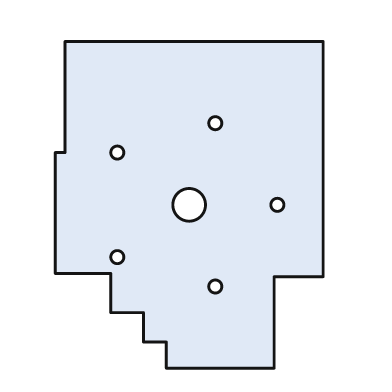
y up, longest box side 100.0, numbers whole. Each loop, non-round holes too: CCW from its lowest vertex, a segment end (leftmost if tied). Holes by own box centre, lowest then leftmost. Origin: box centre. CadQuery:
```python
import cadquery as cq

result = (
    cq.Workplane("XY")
    .moveTo(-7.0, -50.0)
    .lineTo(26.0, -50.0)
    .lineTo(26.0, -22.0)
    .lineTo(41.0, -22.0)
    .lineTo(41.0, 50.0)
    .lineTo(-38.0, 50.0)
    .lineTo(-38.0, 16.0)
    .lineTo(-41.0, 16.0)
    .lineTo(-41.0, -21.0)
    .lineTo(-24.0, -21.0)
    .lineTo(-24.0, -33.0)
    .lineTo(-14.0, -33.0)
    .lineTo(-14.0, -42.0)
    .lineTo(-7.0, -42.0)
    .close()
    .moveTo(8.0, -25.0)
    .circle(2.0)
    .moveTo(-22.0, -16.0)
    .circle(2.0)
    .moveTo(0.0, 0.0)
    .circle(5.0)
    .moveTo(27.0, 0.0)
    .circle(2.0)
    .moveTo(-22.0, 16.0)
    .circle(2.0)
    .moveTo(8.0, 25.0)
    .circle(2.0)
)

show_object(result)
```